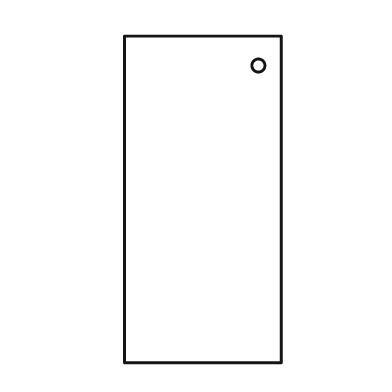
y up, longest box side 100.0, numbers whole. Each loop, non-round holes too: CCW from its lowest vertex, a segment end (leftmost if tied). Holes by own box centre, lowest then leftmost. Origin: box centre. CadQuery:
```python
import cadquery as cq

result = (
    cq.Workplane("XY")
    .moveTo(-24.0, -50.0)
    .lineTo(24.0, -50.0)
    .lineTo(24.0, 50.0)
    .lineTo(-24.0, 50.0)
    .close()
    .moveTo(17.0, 41.0)
    .circle(2.0)
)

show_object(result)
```